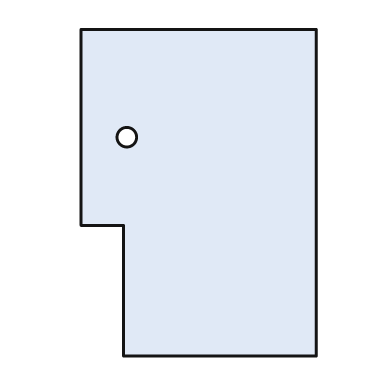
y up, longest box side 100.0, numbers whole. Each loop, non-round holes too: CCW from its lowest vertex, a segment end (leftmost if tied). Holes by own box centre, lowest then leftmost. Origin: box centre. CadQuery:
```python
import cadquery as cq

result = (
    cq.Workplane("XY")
    .moveTo(-23.0, -50.0)
    .lineTo(36.0, -50.0)
    .lineTo(36.0, 50.0)
    .lineTo(-36.0, 50.0)
    .lineTo(-36.0, -10.0)
    .lineTo(-23.0, -10.0)
    .close()
    .moveTo(-22.0, 17.0)
    .circle(3.0)
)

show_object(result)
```